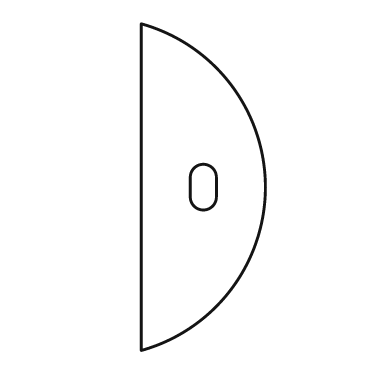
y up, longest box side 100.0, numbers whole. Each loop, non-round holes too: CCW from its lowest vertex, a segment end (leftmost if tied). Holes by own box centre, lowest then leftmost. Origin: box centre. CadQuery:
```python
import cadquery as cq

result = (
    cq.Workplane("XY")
    .moveTo(-19.0, -50.0)
    .threePointArc((19.0, 0.0), (-19.0, 50.0))
    .close()
    .moveTo(-4.0, -3.0)
    .threePointArc((0.0, -7.0), (4.0, -3.0))
    .lineTo(4.0, 3.0)
    .threePointArc((0.0, 7.0), (-4.0, 3.0))
    .close()
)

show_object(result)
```